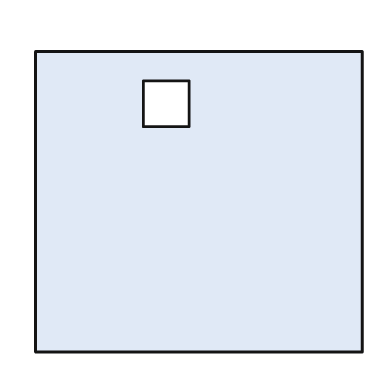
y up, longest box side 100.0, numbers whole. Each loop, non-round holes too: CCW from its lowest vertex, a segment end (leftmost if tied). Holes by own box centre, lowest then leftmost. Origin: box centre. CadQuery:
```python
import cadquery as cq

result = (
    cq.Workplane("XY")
    .moveTo(-50.0, -46.0)
    .lineTo(50.0, -46.0)
    .lineTo(50.0, 46.0)
    .lineTo(-50.0, 46.0)
    .close()
    .moveTo(-17.0, 23.0)
    .lineTo(-3.0, 23.0)
    .lineTo(-3.0, 37.0)
    .lineTo(-17.0, 37.0)
    .close()
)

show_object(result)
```